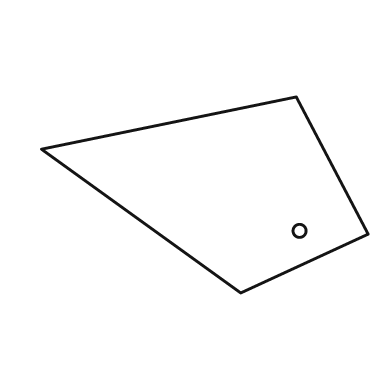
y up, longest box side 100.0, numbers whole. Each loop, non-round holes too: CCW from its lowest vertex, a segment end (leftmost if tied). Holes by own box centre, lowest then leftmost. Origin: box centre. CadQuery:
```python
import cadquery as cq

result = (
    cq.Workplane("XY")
    .moveTo(11.0, -30.0)
    .lineTo(50.0, -12.0)
    .lineTo(28.0, 30.0)
    .lineTo(-50.0, 14.0)
    .close()
    .moveTo(29.0, -11.0)
    .circle(2.0)
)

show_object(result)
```